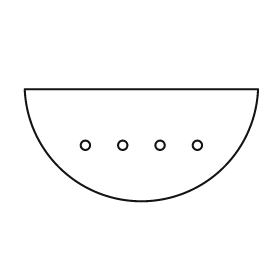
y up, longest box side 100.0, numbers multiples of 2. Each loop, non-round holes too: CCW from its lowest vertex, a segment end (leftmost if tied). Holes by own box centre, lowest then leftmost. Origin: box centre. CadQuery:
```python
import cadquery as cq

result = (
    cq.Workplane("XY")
    .moveTo(-50.0, 24.0)
    .threePointArc((0.0, -24.0), (50.0, 24.0))
    .close()
    .moveTo(-24.0, 0.0)
    .circle(2.0)
    .moveTo(-8.0, 0.0)
    .circle(2.0)
    .moveTo(8.0, 0.0)
    .circle(2.0)
    .moveTo(24.0, 0.0)
    .circle(2.0)
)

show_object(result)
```